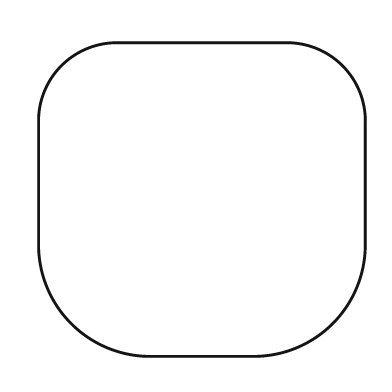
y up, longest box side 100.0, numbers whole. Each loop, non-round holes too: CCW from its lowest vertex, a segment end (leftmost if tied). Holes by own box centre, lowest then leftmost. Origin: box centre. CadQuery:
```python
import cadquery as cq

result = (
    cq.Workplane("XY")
    .moveTo(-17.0, -48.0)
    .lineTo(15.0, -48.0)
    .threePointArc((40.0, -38.0), (50.0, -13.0))
    .lineTo(50.0, 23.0)
    .threePointArc((43.0, 41.0), (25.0, 48.0))
    .lineTo(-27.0, 48.0)
    .threePointArc((-43.0, 41.0), (-50.0, 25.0))
    .lineTo(-50.0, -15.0)
    .threePointArc((-40.0, -38.0), (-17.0, -48.0))
    .close()
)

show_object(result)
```